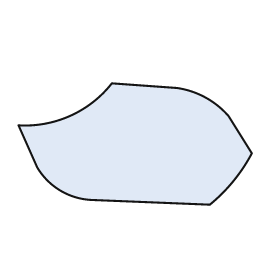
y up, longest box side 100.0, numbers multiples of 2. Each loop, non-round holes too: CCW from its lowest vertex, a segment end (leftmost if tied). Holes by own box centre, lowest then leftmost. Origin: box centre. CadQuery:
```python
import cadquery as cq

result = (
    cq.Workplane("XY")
    .moveTo(32.0, -26.0)
    .threePointArc((42.0, -16.0), (50.0, -4.0))
    .lineTo(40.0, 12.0)
    .threePointArc((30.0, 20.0), (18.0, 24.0))
    .lineTo(-10.0, 26.0)
    .threePointArc((-28.0, 12.0), (-50.0, 8.0))
    .lineTo(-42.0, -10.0)
    .threePointArc((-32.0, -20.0), (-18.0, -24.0))
    .close()
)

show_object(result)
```